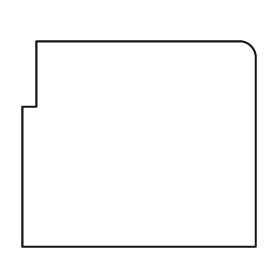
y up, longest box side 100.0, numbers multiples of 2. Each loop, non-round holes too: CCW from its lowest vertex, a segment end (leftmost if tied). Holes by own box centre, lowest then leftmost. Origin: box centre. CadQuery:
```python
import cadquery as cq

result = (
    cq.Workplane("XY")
    .moveTo(-50.0, -44.0)
    .lineTo(50.0, -44.0)
    .lineTo(50.0, 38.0)
    .threePointArc((48.0, 42.0), (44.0, 44.0))
    .lineTo(-44.0, 44.0)
    .lineTo(-44.0, 16.0)
    .lineTo(-50.0, 16.0)
    .close()
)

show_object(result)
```